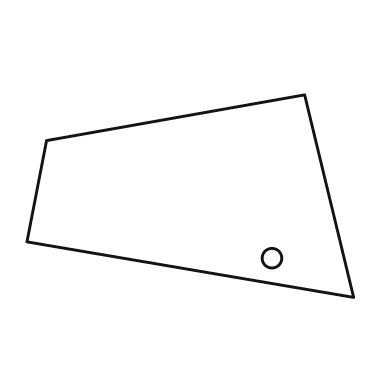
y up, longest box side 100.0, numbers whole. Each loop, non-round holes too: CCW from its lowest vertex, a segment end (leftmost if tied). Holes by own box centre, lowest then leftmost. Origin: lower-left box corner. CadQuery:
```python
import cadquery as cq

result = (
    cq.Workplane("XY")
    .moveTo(100.0, 0.0)
    .lineTo(85.0, 62.0)
    .lineTo(6.0, 48.0)
    .lineTo(0.0, 17.0)
    .close()
    .moveTo(75.0, 12.0)
    .circle(3.0)
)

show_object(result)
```